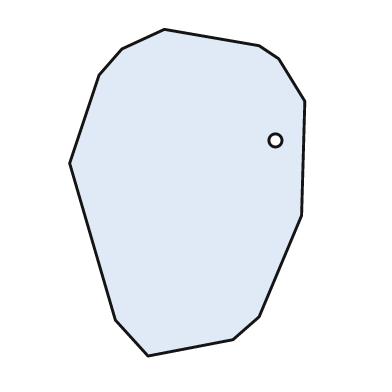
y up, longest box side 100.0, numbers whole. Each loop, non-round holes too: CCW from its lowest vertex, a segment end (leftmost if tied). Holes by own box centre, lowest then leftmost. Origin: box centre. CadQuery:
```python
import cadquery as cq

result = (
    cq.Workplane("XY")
    .moveTo(-12.0, -50.0)
    .lineTo(14.0, -45.0)
    .lineTo(22.0, -38.0)
    .lineTo(35.0, -7.0)
    .lineTo(36.0, 28.0)
    .lineTo(28.0, 41.0)
    .lineTo(22.0, 45.0)
    .lineTo(-7.0, 50.0)
    .lineTo(-20.0, 44.0)
    .lineTo(-27.0, 36.0)
    .lineTo(-36.0, 9.0)
    .lineTo(-22.0, -39.0)
    .close()
    .moveTo(27.0, 16.0)
    .circle(2.0)
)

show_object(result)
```